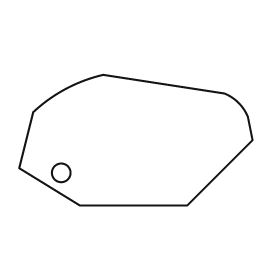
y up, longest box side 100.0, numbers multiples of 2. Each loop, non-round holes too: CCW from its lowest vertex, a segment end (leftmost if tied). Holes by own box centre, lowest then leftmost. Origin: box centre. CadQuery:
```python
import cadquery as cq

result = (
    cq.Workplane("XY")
    .moveTo(-24.0, -28.0)
    .lineTo(22.0, -28.0)
    .lineTo(50.0, 0.0)
    .lineTo(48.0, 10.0)
    .threePointArc((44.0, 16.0), (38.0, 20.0))
    .lineTo(-14.0, 28.0)
    .threePointArc((-30.0, 22.0), (-44.0, 12.0))
    .lineTo(-50.0, -12.0)
    .close()
    .moveTo(-32.0, -14.0)
    .circle(4.0)
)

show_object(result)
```